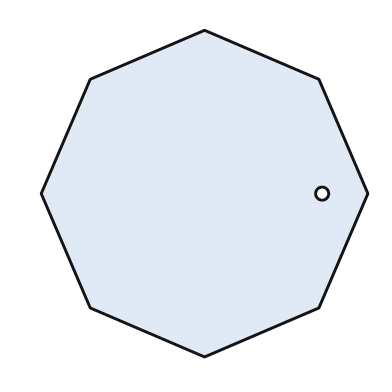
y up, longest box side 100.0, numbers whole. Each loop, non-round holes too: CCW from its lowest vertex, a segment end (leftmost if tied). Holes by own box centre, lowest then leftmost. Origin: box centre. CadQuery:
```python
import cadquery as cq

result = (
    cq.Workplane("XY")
    .moveTo(0.0, -50.0)
    .lineTo(35.0, -35.0)
    .lineTo(50.0, 0.0)
    .lineTo(35.0, 35.0)
    .lineTo(0.0, 50.0)
    .lineTo(-35.0, 35.0)
    .lineTo(-50.0, 0.0)
    .lineTo(-35.0, -35.0)
    .close()
    .moveTo(36.0, 0.0)
    .circle(2.0)
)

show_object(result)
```